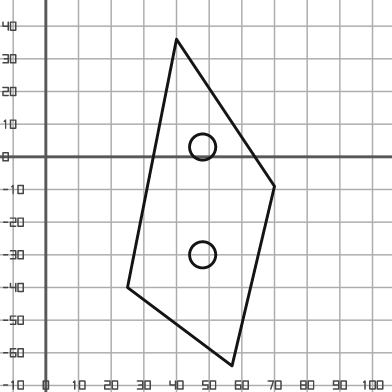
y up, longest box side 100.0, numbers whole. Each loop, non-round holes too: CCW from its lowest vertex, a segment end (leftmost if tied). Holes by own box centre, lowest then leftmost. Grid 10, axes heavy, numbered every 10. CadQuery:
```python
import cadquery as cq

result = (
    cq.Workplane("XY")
    .moveTo(57.0, -64.0)
    .lineTo(70.0, -9.0)
    .lineTo(40.0, 36.0)
    .lineTo(25.0, -40.0)
    .close()
    .moveTo(48.0, -30.0)
    .circle(4.0)
    .moveTo(48.0, 3.0)
    .circle(4.0)
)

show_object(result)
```